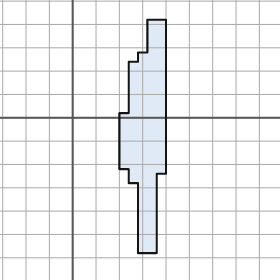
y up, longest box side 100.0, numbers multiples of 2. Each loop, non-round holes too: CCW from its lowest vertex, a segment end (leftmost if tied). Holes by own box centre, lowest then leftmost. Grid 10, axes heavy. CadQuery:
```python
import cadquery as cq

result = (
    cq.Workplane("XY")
    .moveTo(28.0, -58.0)
    .lineTo(36.0, -58.0)
    .lineTo(36.0, -24.0)
    .lineTo(40.0, -24.0)
    .lineTo(40.0, 42.0)
    .lineTo(32.0, 42.0)
    .lineTo(32.0, 28.0)
    .lineTo(28.0, 28.0)
    .lineTo(28.0, 24.0)
    .lineTo(24.0, 24.0)
    .lineTo(24.0, 2.0)
    .lineTo(20.0, 2.0)
    .lineTo(20.0, -22.0)
    .lineTo(24.0, -22.0)
    .lineTo(24.0, -28.0)
    .lineTo(28.0, -28.0)
    .close()
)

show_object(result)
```